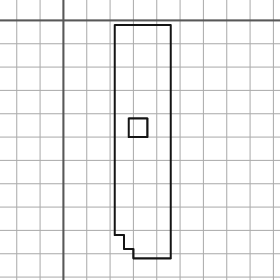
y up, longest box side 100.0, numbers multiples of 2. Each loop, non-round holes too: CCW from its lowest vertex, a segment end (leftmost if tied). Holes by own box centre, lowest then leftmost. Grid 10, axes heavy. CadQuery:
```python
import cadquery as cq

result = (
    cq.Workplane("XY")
    .moveTo(30.0, -102.0)
    .lineTo(46.0, -102.0)
    .lineTo(46.0, -2.0)
    .lineTo(22.0, -2.0)
    .lineTo(22.0, -92.0)
    .lineTo(26.0, -92.0)
    .lineTo(26.0, -98.0)
    .lineTo(30.0, -98.0)
    .close()
    .moveTo(28.0, -50.0)
    .lineTo(36.0, -50.0)
    .lineTo(36.0, -42.0)
    .lineTo(28.0, -42.0)
    .close()
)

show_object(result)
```